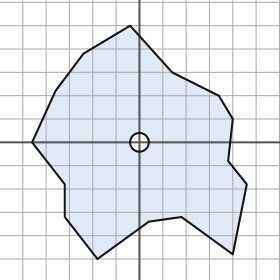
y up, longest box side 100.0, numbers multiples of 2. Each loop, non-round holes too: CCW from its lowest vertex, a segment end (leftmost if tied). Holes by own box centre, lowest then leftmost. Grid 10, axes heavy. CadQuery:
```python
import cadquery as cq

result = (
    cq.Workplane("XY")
    .moveTo(-18.0, -50.0)
    .lineTo(4.0, -34.0)
    .lineTo(18.0, -32.0)
    .lineTo(40.0, -48.0)
    .lineTo(46.0, -18.0)
    .lineTo(38.0, -8.0)
    .lineTo(40.0, 10.0)
    .lineTo(34.0, 20.0)
    .lineTo(14.0, 30.0)
    .lineTo(-4.0, 50.0)
    .lineTo(-24.0, 38.0)
    .lineTo(-36.0, 22.0)
    .lineTo(-46.0, 0.0)
    .lineTo(-32.0, -18.0)
    .lineTo(-32.0, -32.0)
    .close()
    .moveTo(0.0, 0.0)
    .circle(4.0)
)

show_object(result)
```